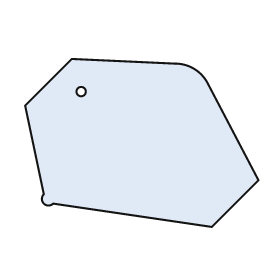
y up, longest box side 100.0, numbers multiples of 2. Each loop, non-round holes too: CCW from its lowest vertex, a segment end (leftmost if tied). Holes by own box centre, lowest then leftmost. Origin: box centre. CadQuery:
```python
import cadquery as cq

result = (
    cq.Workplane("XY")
    .moveTo(30.0, -36.0)
    .lineTo(50.0, -16.0)
    .lineTo(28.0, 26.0)
    .threePointArc((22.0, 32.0), (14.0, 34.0))
    .lineTo(-30.0, 36.0)
    .lineTo(-50.0, 16.0)
    .lineTo(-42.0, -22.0)
    .threePointArc((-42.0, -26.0), (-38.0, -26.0))
    .close()
    .moveTo(-26.0, 22.0)
    .circle(2.0)
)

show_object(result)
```